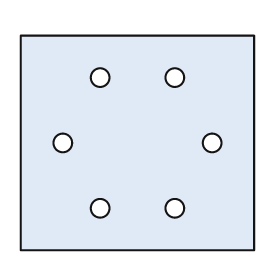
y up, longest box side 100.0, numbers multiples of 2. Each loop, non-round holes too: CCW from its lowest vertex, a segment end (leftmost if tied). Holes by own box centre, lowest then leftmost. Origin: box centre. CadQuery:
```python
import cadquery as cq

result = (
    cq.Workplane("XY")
    .moveTo(-50.0, -46.0)
    .lineTo(50.0, -46.0)
    .lineTo(50.0, 46.0)
    .lineTo(-50.0, 46.0)
    .close()
    .moveTo(-16.0, -28.0)
    .circle(4.0)
    .moveTo(16.0, -28.0)
    .circle(4.0)
    .moveTo(-32.0, 0.0)
    .circle(4.0)
    .moveTo(32.0, 0.0)
    .circle(4.0)
    .moveTo(-16.0, 28.0)
    .circle(4.0)
    .moveTo(16.0, 28.0)
    .circle(4.0)
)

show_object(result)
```